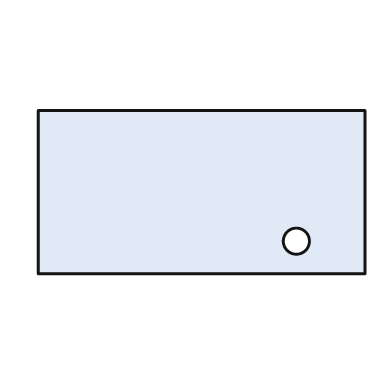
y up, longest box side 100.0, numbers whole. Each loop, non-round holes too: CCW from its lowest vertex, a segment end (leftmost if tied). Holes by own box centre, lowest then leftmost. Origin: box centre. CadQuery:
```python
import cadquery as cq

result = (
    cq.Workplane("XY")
    .moveTo(-50.0, -25.0)
    .lineTo(50.0, -25.0)
    .lineTo(50.0, 25.0)
    .lineTo(-50.0, 25.0)
    .close()
    .moveTo(29.0, -15.0)
    .circle(4.0)
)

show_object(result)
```